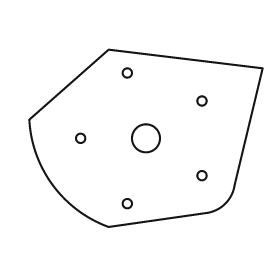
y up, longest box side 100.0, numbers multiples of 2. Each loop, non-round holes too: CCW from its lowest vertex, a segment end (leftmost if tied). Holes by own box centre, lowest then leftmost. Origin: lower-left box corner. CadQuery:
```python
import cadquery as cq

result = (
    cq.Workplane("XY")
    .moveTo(34.0, 0.0)
    .lineTo(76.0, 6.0)
    .threePointArc((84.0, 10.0), (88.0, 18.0))
    .lineTo(100.0, 68.0)
    .lineTo(34.0, 76.0)
    .lineTo(0.0, 46.0)
    .threePointArc((10.0, 18.0), (34.0, 0.0))
    .close()
    .moveTo(42.0, 10.0)
    .circle(2.0)
    .moveTo(74.0, 22.0)
    .circle(2.0)
    .moveTo(22.0, 38.0)
    .circle(2.0)
    .moveTo(50.0, 38.0)
    .circle(6.0)
    .moveTo(74.0, 54.0)
    .circle(2.0)
    .moveTo(42.0, 66.0)
    .circle(2.0)
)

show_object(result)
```